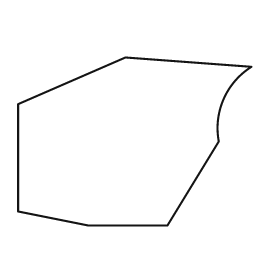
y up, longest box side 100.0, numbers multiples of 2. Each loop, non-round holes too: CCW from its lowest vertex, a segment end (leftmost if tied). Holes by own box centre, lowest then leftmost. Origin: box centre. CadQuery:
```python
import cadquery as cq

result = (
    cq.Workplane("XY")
    .moveTo(-20.0, -36.0)
    .lineTo(14.0, -36.0)
    .lineTo(36.0, 0.0)
    .threePointArc((38.0, 18.0), (50.0, 32.0))
    .lineTo(-4.0, 36.0)
    .lineTo(-50.0, 16.0)
    .lineTo(-50.0, -30.0)
    .close()
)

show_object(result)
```